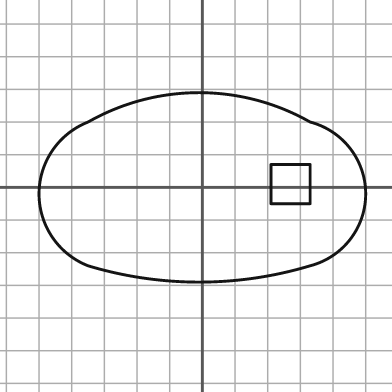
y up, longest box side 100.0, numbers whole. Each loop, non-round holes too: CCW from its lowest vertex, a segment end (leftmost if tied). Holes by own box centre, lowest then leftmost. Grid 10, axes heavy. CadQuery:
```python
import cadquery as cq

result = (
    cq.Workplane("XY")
    .moveTo(-35.0, -24.0)
    .threePointArc((-1.0, -29.0), (33.0, -24.0))
    .threePointArc((50.0, -2.0), (33.0, 20.0))
    .threePointArc((-1.0, 29.0), (-35.0, 20.0))
    .threePointArc((-50.0, -2.0), (-35.0, -24.0))
    .close()
    .moveTo(21.0, -5.0)
    .lineTo(33.0, -5.0)
    .lineTo(33.0, 7.0)
    .lineTo(21.0, 7.0)
    .close()
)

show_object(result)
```